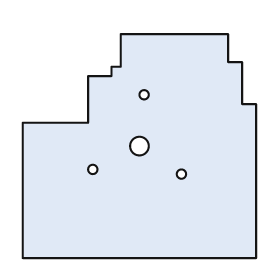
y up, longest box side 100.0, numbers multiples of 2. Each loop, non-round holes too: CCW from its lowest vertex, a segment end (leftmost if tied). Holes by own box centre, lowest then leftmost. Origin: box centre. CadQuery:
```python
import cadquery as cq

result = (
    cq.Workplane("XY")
    .moveTo(-50.0, -48.0)
    .lineTo(50.0, -48.0)
    .lineTo(50.0, 18.0)
    .lineTo(44.0, 18.0)
    .lineTo(44.0, 36.0)
    .lineTo(38.0, 36.0)
    .lineTo(38.0, 48.0)
    .lineTo(-8.0, 48.0)
    .lineTo(-8.0, 34.0)
    .lineTo(-12.0, 34.0)
    .lineTo(-12.0, 30.0)
    .lineTo(-22.0, 30.0)
    .lineTo(-22.0, 10.0)
    .lineTo(-50.0, 10.0)
    .close()
    .moveTo(18.0, -12.0)
    .circle(2.0)
    .moveTo(-20.0, -10.0)
    .circle(2.0)
    .moveTo(0.0, 0.0)
    .circle(4.0)
    .moveTo(2.0, 22.0)
    .circle(2.0)
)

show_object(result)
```